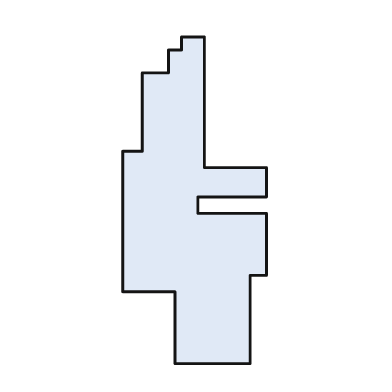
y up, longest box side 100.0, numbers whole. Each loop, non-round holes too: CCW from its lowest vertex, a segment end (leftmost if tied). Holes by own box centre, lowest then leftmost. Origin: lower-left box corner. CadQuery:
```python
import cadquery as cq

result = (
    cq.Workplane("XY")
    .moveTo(16.0, 0.0)
    .lineTo(39.0, 0.0)
    .lineTo(39.0, 27.0)
    .lineTo(44.0, 27.0)
    .lineTo(44.0, 46.0)
    .lineTo(23.0, 46.0)
    .lineTo(23.0, 51.0)
    .lineTo(44.0, 51.0)
    .lineTo(44.0, 60.0)
    .lineTo(25.0, 60.0)
    .lineTo(25.0, 100.0)
    .lineTo(18.0, 100.0)
    .lineTo(18.0, 96.0)
    .lineTo(14.0, 96.0)
    .lineTo(14.0, 89.0)
    .lineTo(6.0, 89.0)
    .lineTo(6.0, 65.0)
    .lineTo(0.0, 65.0)
    .lineTo(0.0, 22.0)
    .lineTo(16.0, 22.0)
    .close()
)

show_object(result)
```